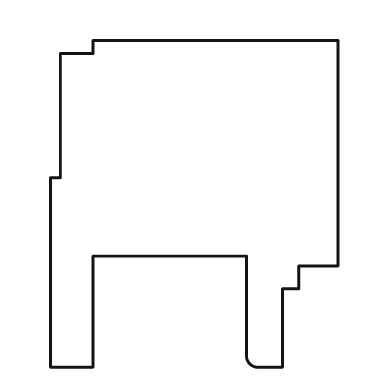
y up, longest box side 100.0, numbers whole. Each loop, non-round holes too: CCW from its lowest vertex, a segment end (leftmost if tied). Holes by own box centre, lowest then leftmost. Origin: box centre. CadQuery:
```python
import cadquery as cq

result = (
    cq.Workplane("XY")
    .moveTo(-44.0, -50.0)
    .lineTo(-31.0, -50.0)
    .lineTo(-31.0, -16.0)
    .lineTo(16.0, -16.0)
    .lineTo(16.0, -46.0)
    .threePointArc((17.0, -49.0), (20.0, -50.0))
    .lineTo(27.0, -50.0)
    .lineTo(27.0, -26.0)
    .lineTo(32.0, -26.0)
    .lineTo(32.0, -19.0)
    .lineTo(44.0, -19.0)
    .lineTo(44.0, 50.0)
    .lineTo(-31.0, 50.0)
    .lineTo(-31.0, 46.0)
    .lineTo(-41.0, 46.0)
    .lineTo(-41.0, 8.0)
    .lineTo(-44.0, 8.0)
    .close()
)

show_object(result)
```